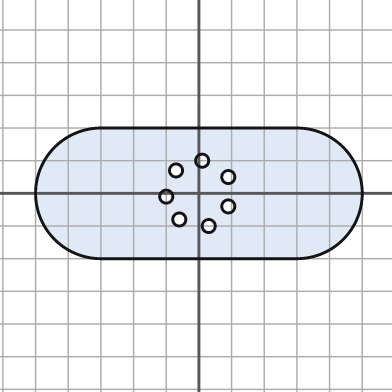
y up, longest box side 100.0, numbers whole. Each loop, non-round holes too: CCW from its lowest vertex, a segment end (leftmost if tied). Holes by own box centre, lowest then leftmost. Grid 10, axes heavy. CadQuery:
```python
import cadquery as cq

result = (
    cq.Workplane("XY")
    .moveTo(-30.0, -20.0)
    .lineTo(30.0, -20.0)
    .threePointArc((50.0, 0.0), (30.0, 20.0))
    .lineTo(-30.0, 20.0)
    .threePointArc((-50.0, 0.0), (-30.0, -20.0))
    .close()
    .moveTo(3.0, -10.0)
    .circle(2.0)
    .moveTo(-6.0, -8.0)
    .circle(2.0)
    .moveTo(9.0, -4.0)
    .circle(2.0)
    .moveTo(-10.0, -1.0)
    .circle(2.0)
    .moveTo(9.0, 5.0)
    .circle(2.0)
    .moveTo(-7.0, 7.0)
    .circle(2.0)
    .moveTo(1.0, 10.0)
    .circle(2.0)
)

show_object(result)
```